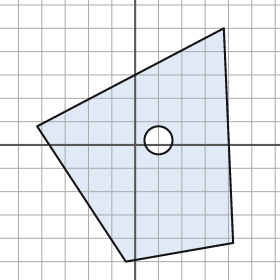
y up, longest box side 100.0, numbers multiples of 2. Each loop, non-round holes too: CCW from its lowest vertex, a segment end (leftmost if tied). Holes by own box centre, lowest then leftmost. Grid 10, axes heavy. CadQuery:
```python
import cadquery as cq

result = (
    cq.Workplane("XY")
    .moveTo(-4.0, -50.0)
    .lineTo(42.0, -42.0)
    .lineTo(38.0, 50.0)
    .lineTo(-42.0, 8.0)
    .close()
    .moveTo(10.0, 2.0)
    .circle(6.0)
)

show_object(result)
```